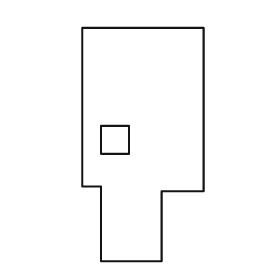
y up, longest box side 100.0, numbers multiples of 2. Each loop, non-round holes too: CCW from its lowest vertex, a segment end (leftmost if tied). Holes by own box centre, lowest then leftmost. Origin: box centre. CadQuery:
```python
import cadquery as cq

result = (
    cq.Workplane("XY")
    .moveTo(-18.0, -50.0)
    .lineTo(8.0, -50.0)
    .lineTo(8.0, -20.0)
    .lineTo(26.0, -20.0)
    .lineTo(26.0, 50.0)
    .lineTo(-26.0, 50.0)
    .lineTo(-26.0, -18.0)
    .lineTo(-18.0, -18.0)
    .close()
    .moveTo(-18.0, -4.0)
    .lineTo(-6.0, -4.0)
    .lineTo(-6.0, 8.0)
    .lineTo(-18.0, 8.0)
    .close()
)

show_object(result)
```